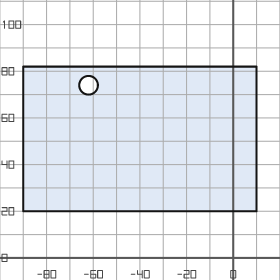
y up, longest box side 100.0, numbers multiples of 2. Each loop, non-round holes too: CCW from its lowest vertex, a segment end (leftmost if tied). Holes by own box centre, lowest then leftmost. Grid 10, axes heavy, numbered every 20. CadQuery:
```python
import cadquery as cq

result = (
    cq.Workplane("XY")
    .moveTo(-90.0, 20.0)
    .lineTo(10.0, 20.0)
    .lineTo(10.0, 82.0)
    .lineTo(-90.0, 82.0)
    .close()
    .moveTo(-62.0, 74.0)
    .circle(4.0)
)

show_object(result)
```